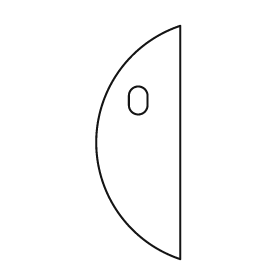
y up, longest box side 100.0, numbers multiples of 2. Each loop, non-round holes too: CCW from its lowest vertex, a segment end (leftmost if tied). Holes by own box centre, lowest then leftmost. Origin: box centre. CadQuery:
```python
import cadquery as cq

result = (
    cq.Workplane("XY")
    .moveTo(18.0, -50.0)
    .lineTo(18.0, 50.0)
    .threePointArc((-18.0, 0.0), (18.0, -50.0))
    .close()
    .moveTo(-4.0, 16.0)
    .threePointArc((0.0, 12.0), (4.0, 16.0))
    .lineTo(4.0, 20.0)
    .threePointArc((0.0, 24.0), (-4.0, 20.0))
    .close()
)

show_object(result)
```